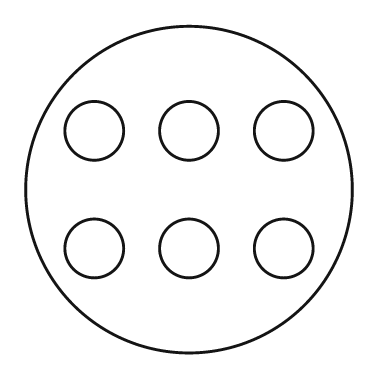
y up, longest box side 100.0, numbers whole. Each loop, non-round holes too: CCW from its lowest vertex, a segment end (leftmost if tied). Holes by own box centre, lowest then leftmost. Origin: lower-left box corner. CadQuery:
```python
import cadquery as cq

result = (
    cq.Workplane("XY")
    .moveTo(50.0, 50.0)
    .circle(50.0)
    .moveTo(21.0, 32.0)
    .circle(9.0)
    .moveTo(50.0, 32.0)
    .circle(9.0)
    .moveTo(79.0, 32.0)
    .circle(9.0)
    .moveTo(21.0, 68.0)
    .circle(9.0)
    .moveTo(50.0, 68.0)
    .circle(9.0)
    .moveTo(79.0, 68.0)
    .circle(9.0)
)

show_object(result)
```